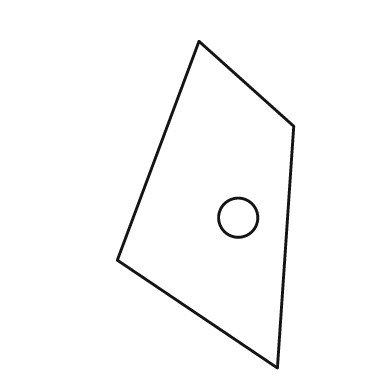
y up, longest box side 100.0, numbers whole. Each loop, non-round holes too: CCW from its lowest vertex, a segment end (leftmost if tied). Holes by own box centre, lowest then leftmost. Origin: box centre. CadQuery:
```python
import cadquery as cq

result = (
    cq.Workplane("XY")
    .moveTo(22.0, -50.0)
    .lineTo(27.0, 24.0)
    .lineTo(-2.0, 50.0)
    .lineTo(-27.0, -17.0)
    .close()
    .moveTo(10.0, -4.0)
    .circle(6.0)
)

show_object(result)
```